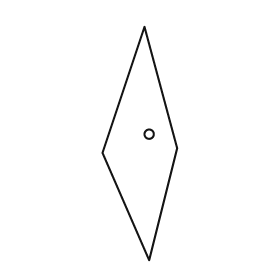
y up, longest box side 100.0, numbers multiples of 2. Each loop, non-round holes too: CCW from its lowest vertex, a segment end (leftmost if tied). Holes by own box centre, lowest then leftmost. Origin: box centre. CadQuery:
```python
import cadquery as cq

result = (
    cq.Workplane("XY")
    .moveTo(4.0, -50.0)
    .lineTo(16.0, -2.0)
    .lineTo(2.0, 50.0)
    .lineTo(-16.0, -4.0)
    .close()
    .moveTo(4.0, 4.0)
    .circle(2.0)
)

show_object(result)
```